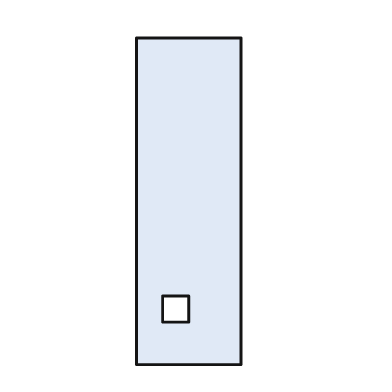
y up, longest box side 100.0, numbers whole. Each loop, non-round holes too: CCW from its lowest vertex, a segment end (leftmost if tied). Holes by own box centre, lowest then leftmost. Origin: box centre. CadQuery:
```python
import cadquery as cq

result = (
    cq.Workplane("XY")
    .moveTo(-16.0, -50.0)
    .lineTo(16.0, -50.0)
    .lineTo(16.0, 50.0)
    .lineTo(-16.0, 50.0)
    .close()
    .moveTo(-8.0, -37.0)
    .lineTo(0.0, -37.0)
    .lineTo(0.0, -29.0)
    .lineTo(-8.0, -29.0)
    .close()
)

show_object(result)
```